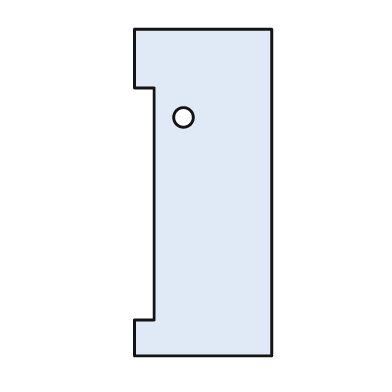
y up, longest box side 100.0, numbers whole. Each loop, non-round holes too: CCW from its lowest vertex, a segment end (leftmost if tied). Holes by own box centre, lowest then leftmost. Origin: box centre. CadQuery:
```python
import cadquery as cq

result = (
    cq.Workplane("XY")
    .moveTo(-21.0, -50.0)
    .lineTo(21.0, -50.0)
    .lineTo(21.0, 50.0)
    .lineTo(-21.0, 50.0)
    .lineTo(-21.0, 32.0)
    .lineTo(-15.0, 32.0)
    .lineTo(-15.0, -39.0)
    .lineTo(-21.0, -39.0)
    .close()
    .moveTo(-6.0, 23.0)
    .circle(3.0)
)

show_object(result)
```